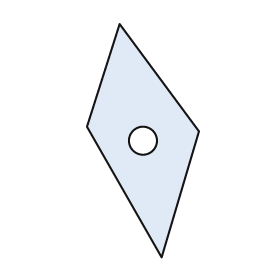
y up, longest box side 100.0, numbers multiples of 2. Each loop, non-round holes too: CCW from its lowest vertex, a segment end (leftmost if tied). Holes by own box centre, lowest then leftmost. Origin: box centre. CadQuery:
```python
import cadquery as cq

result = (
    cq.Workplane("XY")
    .moveTo(8.0, -50.0)
    .lineTo(24.0, 4.0)
    .lineTo(-10.0, 50.0)
    .lineTo(-24.0, 6.0)
    .close()
    .moveTo(0.0, 0.0)
    .circle(6.0)
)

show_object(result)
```